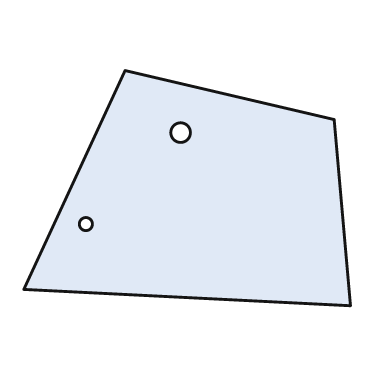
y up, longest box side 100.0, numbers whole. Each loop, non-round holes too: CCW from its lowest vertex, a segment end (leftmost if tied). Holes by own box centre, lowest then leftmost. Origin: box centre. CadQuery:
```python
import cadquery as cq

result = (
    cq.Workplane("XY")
    .moveTo(50.0, -36.0)
    .lineTo(45.0, 21.0)
    .lineTo(-19.0, 36.0)
    .lineTo(-50.0, -31.0)
    .close()
    .moveTo(-31.0, -11.0)
    .circle(2.0)
    .moveTo(-2.0, 17.0)
    .circle(3.0)
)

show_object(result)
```